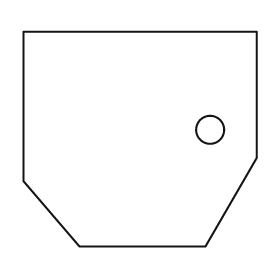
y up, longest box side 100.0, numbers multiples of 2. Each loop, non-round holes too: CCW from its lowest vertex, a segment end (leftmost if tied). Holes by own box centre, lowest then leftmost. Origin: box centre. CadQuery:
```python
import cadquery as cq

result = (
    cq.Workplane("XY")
    .moveTo(-26.0, -46.0)
    .lineTo(28.0, -46.0)
    .lineTo(50.0, -8.0)
    .lineTo(50.0, 46.0)
    .lineTo(-50.0, 46.0)
    .lineTo(-50.0, -18.0)
    .close()
    .moveTo(30.0, 4.0)
    .circle(6.0)
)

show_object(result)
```